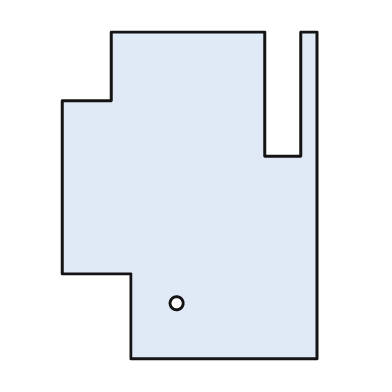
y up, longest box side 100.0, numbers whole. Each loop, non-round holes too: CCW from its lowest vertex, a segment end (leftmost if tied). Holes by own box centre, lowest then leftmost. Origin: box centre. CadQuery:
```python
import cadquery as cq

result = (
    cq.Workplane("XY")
    .moveTo(-18.0, -50.0)
    .lineTo(39.0, -50.0)
    .lineTo(39.0, 50.0)
    .lineTo(34.0, 50.0)
    .lineTo(34.0, 12.0)
    .lineTo(23.0, 12.0)
    .lineTo(23.0, 50.0)
    .lineTo(-24.0, 50.0)
    .lineTo(-24.0, 29.0)
    .lineTo(-39.0, 29.0)
    .lineTo(-39.0, -24.0)
    .lineTo(-18.0, -24.0)
    .close()
    .moveTo(-4.0, -33.0)
    .circle(2.0)
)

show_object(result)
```